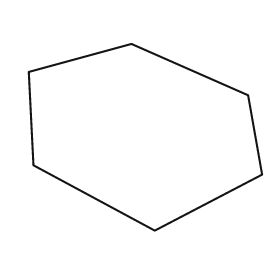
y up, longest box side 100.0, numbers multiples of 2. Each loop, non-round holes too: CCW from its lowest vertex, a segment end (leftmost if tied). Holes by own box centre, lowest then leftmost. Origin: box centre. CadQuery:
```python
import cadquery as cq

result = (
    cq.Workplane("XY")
    .moveTo(4.0, -40.0)
    .lineTo(50.0, -16.0)
    .lineTo(44.0, 18.0)
    .lineTo(-6.0, 40.0)
    .lineTo(-50.0, 28.0)
    .lineTo(-48.0, -12.0)
    .close()
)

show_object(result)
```